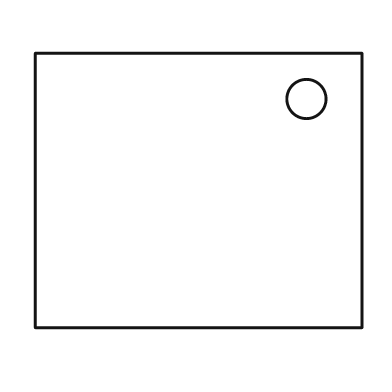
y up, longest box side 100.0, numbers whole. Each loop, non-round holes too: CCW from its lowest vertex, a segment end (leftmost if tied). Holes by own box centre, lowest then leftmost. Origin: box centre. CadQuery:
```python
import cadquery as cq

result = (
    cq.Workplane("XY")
    .moveTo(-50.0, -42.0)
    .lineTo(50.0, -42.0)
    .lineTo(50.0, 42.0)
    .lineTo(-50.0, 42.0)
    .close()
    .moveTo(33.0, 28.0)
    .circle(6.0)
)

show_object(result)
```